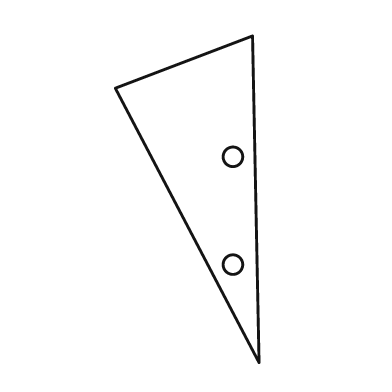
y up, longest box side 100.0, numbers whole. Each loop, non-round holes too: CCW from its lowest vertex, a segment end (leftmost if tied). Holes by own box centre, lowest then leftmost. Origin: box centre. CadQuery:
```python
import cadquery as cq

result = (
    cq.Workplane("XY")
    .moveTo(22.0, -50.0)
    .lineTo(20.0, 50.0)
    .lineTo(-22.0, 34.0)
    .close()
    .moveTo(14.0, -20.0)
    .circle(3.0)
    .moveTo(14.0, 13.0)
    .circle(3.0)
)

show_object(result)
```